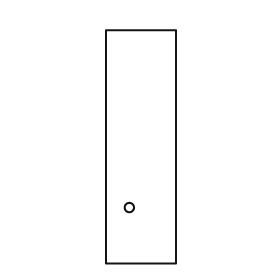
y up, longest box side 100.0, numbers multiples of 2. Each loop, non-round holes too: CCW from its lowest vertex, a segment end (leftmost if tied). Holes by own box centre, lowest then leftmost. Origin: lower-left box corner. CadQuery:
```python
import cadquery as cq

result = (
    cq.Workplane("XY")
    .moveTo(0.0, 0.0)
    .lineTo(30.0, 0.0)
    .lineTo(30.0, 100.0)
    .lineTo(0.0, 100.0)
    .close()
    .moveTo(10.0, 24.0)
    .circle(2.0)
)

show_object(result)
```